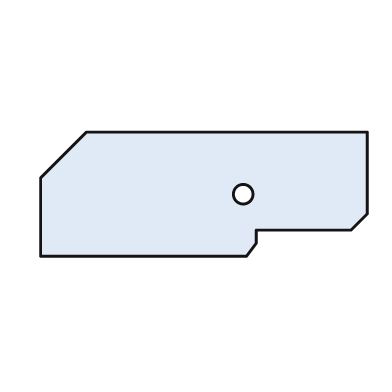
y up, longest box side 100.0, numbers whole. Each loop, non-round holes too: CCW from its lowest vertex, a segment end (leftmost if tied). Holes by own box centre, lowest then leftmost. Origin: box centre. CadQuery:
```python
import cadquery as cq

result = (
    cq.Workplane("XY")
    .moveTo(-50.0, -19.0)
    .lineTo(13.0, -19.0)
    .lineTo(16.0, -15.0)
    .lineTo(16.0, -11.0)
    .lineTo(45.0, -11.0)
    .lineTo(50.0, -6.0)
    .lineTo(50.0, 19.0)
    .lineTo(-36.0, 19.0)
    .lineTo(-50.0, 5.0)
    .close()
    .moveTo(12.0, 0.0)
    .circle(3.0)
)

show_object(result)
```